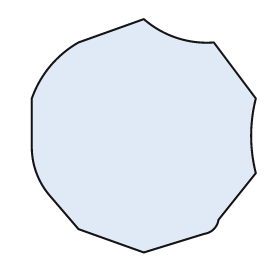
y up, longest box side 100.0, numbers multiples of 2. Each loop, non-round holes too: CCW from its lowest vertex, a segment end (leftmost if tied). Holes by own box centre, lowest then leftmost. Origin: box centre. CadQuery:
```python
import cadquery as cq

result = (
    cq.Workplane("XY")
    .moveTo(0.0, -50.0)
    .lineTo(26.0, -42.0)
    .threePointArc((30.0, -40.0), (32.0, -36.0))
    .lineTo(48.0, -16.0)
    .threePointArc((46.0, 0.0), (48.0, 16.0))
    .lineTo(30.0, 40.0)
    .threePointArc((14.0, 42.0), (0.0, 50.0))
    .lineTo(-28.0, 40.0)
    .threePointArc((-40.0, 30.0), (-48.0, 16.0))
    .lineTo(-48.0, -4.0)
    .threePointArc((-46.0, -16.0), (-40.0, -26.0))
    .lineTo(-28.0, -40.0)
    .close()
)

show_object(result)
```